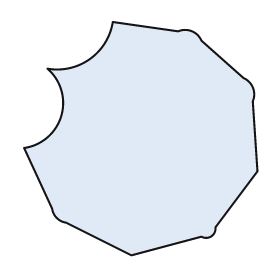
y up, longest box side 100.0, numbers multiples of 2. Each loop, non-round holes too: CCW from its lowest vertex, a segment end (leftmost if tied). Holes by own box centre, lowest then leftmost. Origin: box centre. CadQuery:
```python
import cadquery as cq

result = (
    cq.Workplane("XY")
    .moveTo(-4.0, -50.0)
    .lineTo(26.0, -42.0)
    .threePointArc((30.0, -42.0), (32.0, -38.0))
    .lineTo(50.0, -14.0)
    .lineTo(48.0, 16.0)
    .threePointArc((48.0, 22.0), (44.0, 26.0))
    .lineTo(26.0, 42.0)
    .threePointArc((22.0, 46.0), (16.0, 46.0))
    .lineTo(-12.0, 50.0)
    .threePointArc((-22.0, 34.0), (-40.0, 30.0))
    .threePointArc((-34.0, 10.0), (-50.0, -4.0))
    .lineTo(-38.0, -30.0)
    .threePointArc((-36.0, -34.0), (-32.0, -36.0))
    .close()
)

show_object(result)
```